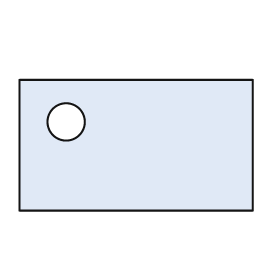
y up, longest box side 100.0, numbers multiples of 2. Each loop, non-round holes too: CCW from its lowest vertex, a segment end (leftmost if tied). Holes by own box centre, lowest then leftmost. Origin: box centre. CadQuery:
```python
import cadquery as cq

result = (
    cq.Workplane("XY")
    .moveTo(-50.0, -28.0)
    .lineTo(50.0, -28.0)
    .lineTo(50.0, 28.0)
    .lineTo(-50.0, 28.0)
    .close()
    .moveTo(-30.0, 10.0)
    .circle(8.0)
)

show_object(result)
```